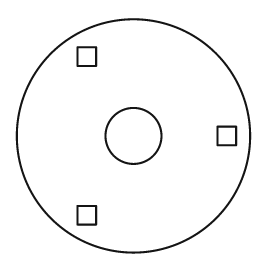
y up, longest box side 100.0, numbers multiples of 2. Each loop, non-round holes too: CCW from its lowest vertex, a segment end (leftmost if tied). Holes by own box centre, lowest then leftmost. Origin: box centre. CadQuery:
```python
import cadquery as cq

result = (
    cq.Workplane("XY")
    .moveTo(0.0, 0.0)
    .circle(50.0)
    .moveTo(-24.0, -38.0)
    .lineTo(-16.0, -38.0)
    .lineTo(-16.0, -30.0)
    .lineTo(-24.0, -30.0)
    .close()
    .moveTo(0.0, 0.0)
    .circle(12.0)
    .moveTo(36.0, -4.0)
    .lineTo(44.0, -4.0)
    .lineTo(44.0, 4.0)
    .lineTo(36.0, 4.0)
    .close()
    .moveTo(-24.0, 30.0)
    .lineTo(-16.0, 30.0)
    .lineTo(-16.0, 38.0)
    .lineTo(-24.0, 38.0)
    .close()
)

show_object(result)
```